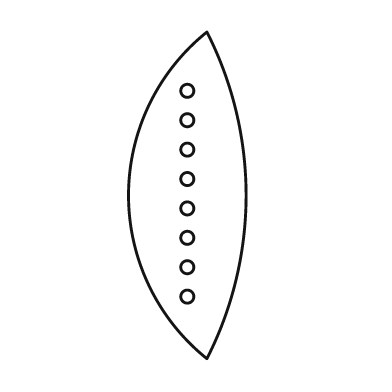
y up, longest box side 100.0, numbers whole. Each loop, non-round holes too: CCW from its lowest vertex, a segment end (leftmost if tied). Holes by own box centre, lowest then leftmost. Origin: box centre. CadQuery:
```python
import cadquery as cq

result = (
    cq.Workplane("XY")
    .moveTo(6.0, -50.0)
    .threePointArc((18.0, 0.0), (6.0, 50.0))
    .threePointArc((-18.0, 0.0), (6.0, -50.0))
    .close()
    .moveTo(0.0, -31.0)
    .circle(2.0)
    .moveTo(0.0, -22.0)
    .circle(2.0)
    .moveTo(0.0, -13.0)
    .circle(2.0)
    .moveTo(0.0, -4.0)
    .circle(2.0)
    .moveTo(0.0, 5.0)
    .circle(2.0)
    .moveTo(0.0, 14.0)
    .circle(2.0)
    .moveTo(0.0, 23.0)
    .circle(2.0)
    .moveTo(0.0, 32.0)
    .circle(2.0)
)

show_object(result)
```